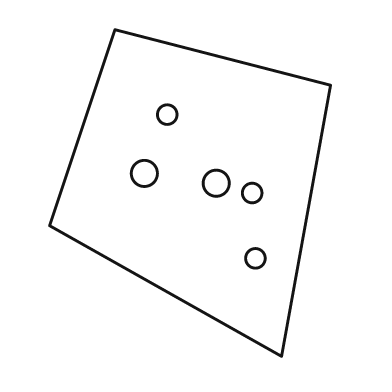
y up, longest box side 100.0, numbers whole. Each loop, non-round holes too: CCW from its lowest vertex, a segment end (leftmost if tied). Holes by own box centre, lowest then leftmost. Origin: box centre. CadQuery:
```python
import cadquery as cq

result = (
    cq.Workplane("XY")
    .moveTo(28.0, -50.0)
    .lineTo(43.0, 33.0)
    .lineTo(-23.0, 50.0)
    .lineTo(-43.0, -10.0)
    .close()
    .moveTo(20.0, -20.0)
    .circle(3.0)
    .moveTo(19.0, 0.0)
    .circle(3.0)
    .moveTo(8.0, 3.0)
    .circle(4.0)
    .moveTo(-14.0, 6.0)
    .circle(4.0)
    .moveTo(-7.0, 24.0)
    .circle(3.0)
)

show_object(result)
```